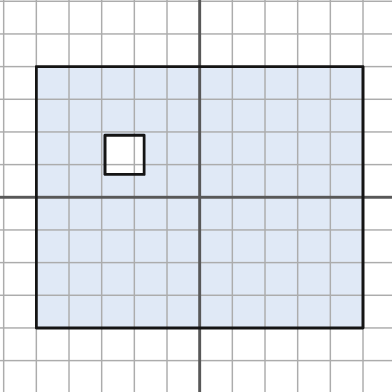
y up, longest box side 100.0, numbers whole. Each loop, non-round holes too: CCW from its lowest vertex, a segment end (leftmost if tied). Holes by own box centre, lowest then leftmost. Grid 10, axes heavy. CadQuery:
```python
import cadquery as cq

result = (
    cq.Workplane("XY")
    .moveTo(-50.0, -40.0)
    .lineTo(50.0, -40.0)
    .lineTo(50.0, 40.0)
    .lineTo(-50.0, 40.0)
    .close()
    .moveTo(-29.0, 7.0)
    .lineTo(-17.0, 7.0)
    .lineTo(-17.0, 19.0)
    .lineTo(-29.0, 19.0)
    .close()
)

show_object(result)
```